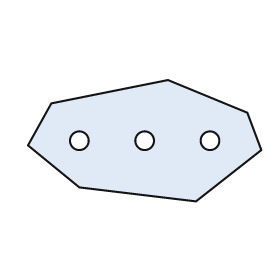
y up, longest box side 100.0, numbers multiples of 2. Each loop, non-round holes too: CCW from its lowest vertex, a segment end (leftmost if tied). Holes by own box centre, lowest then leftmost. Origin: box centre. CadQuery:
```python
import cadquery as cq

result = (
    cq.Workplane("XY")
    .moveTo(22.0, -26.0)
    .lineTo(50.0, -4.0)
    .lineTo(44.0, 12.0)
    .lineTo(10.0, 26.0)
    .lineTo(-40.0, 16.0)
    .lineTo(-50.0, -2.0)
    .lineTo(-28.0, -20.0)
    .close()
    .moveTo(-28.0, 0.0)
    .circle(4.0)
    .moveTo(0.0, 0.0)
    .circle(4.0)
    .moveTo(28.0, 0.0)
    .circle(4.0)
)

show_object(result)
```